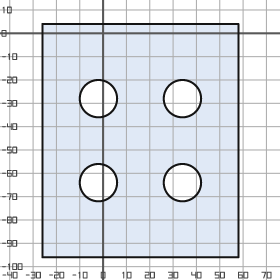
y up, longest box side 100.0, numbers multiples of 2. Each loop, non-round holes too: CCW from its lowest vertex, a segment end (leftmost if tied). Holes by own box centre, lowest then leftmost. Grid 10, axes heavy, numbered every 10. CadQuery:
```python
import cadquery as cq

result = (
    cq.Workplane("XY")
    .moveTo(-26.0, -96.0)
    .lineTo(58.0, -96.0)
    .lineTo(58.0, 4.0)
    .lineTo(-26.0, 4.0)
    .close()
    .moveTo(-2.0, -64.0)
    .circle(8.0)
    .moveTo(34.0, -64.0)
    .circle(8.0)
    .moveTo(-2.0, -28.0)
    .circle(8.0)
    .moveTo(34.0, -28.0)
    .circle(8.0)
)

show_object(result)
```